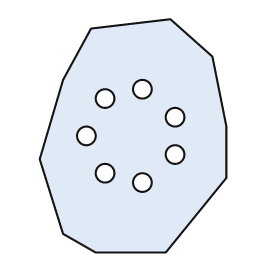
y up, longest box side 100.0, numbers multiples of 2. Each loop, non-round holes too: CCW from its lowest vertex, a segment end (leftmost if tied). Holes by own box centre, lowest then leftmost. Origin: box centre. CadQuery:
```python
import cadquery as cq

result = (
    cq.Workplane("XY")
    .moveTo(-16.0, -50.0)
    .lineTo(14.0, -50.0)
    .lineTo(40.0, -18.0)
    .lineTo(40.0, 4.0)
    .lineTo(34.0, 34.0)
    .lineTo(16.0, 50.0)
    .lineTo(-18.0, 46.0)
    .lineTo(-30.0, 24.0)
    .lineTo(-40.0, -10.0)
    .lineTo(-30.0, -42.0)
    .close()
    .moveTo(4.0, -20.0)
    .circle(4.0)
    .moveTo(-12.0, -16.0)
    .circle(4.0)
    .moveTo(18.0, -8.0)
    .circle(4.0)
    .moveTo(-20.0, 0.0)
    .circle(4.0)
    .moveTo(18.0, 8.0)
    .circle(4.0)
    .moveTo(-12.0, 16.0)
    .circle(4.0)
    .moveTo(4.0, 20.0)
    .circle(4.0)
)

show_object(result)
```